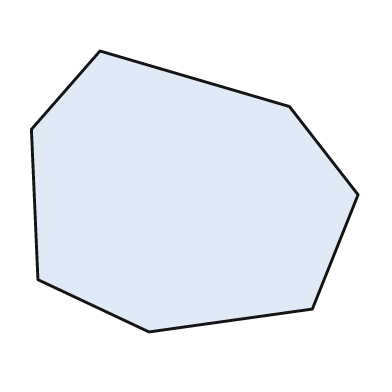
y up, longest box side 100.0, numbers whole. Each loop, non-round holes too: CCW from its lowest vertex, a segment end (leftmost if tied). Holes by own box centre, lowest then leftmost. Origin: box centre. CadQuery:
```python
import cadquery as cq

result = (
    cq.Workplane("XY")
    .moveTo(-14.0, -43.0)
    .lineTo(36.0, -36.0)
    .lineTo(50.0, -1.0)
    .lineTo(29.0, 26.0)
    .lineTo(-29.0, 43.0)
    .lineTo(-50.0, 19.0)
    .lineTo(-48.0, -27.0)
    .close()
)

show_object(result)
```